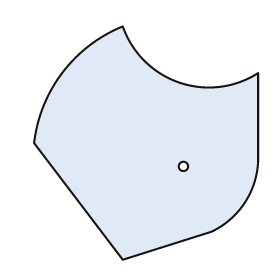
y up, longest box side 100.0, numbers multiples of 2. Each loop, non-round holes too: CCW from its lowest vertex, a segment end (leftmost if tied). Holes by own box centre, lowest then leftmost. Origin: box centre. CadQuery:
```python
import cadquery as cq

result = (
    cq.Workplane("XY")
    .moveTo(-10.0, -50.0)
    .lineTo(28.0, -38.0)
    .threePointArc((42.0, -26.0), (48.0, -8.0))
    .lineTo(48.0, 30.0)
    .threePointArc((14.0, 26.0), (-10.0, 50.0))
    .threePointArc((-36.0, 30.0), (-48.0, 0.0))
    .close()
    .moveTo(16.0, -10.0)
    .circle(2.0)
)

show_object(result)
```